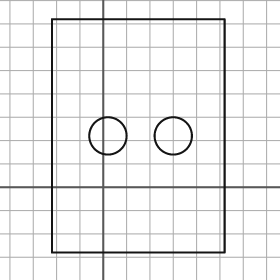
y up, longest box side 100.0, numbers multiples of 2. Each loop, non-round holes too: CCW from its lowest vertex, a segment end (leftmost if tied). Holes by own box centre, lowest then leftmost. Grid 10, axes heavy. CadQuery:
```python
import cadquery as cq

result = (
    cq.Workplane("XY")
    .moveTo(-22.0, -28.0)
    .lineTo(52.0, -28.0)
    .lineTo(52.0, 72.0)
    .lineTo(-22.0, 72.0)
    .close()
    .moveTo(2.0, 22.0)
    .circle(8.0)
    .moveTo(30.0, 22.0)
    .circle(8.0)
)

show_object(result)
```